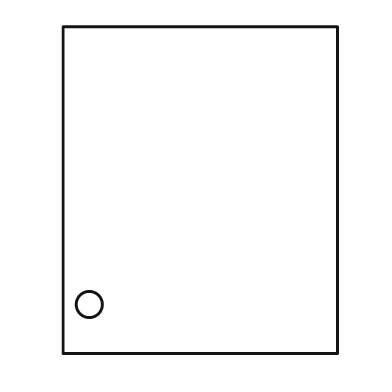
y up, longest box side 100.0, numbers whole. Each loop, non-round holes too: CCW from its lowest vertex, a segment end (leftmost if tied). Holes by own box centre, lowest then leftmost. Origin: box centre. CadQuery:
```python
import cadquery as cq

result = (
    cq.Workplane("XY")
    .moveTo(-42.0, -50.0)
    .lineTo(42.0, -50.0)
    .lineTo(42.0, 50.0)
    .lineTo(-42.0, 50.0)
    .close()
    .moveTo(-34.0, -35.0)
    .circle(4.0)
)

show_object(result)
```